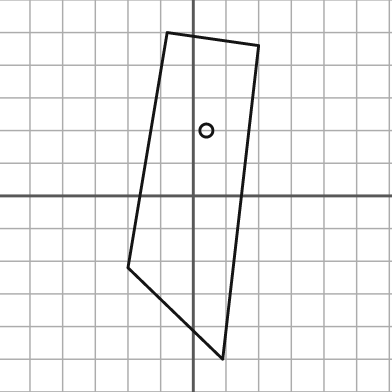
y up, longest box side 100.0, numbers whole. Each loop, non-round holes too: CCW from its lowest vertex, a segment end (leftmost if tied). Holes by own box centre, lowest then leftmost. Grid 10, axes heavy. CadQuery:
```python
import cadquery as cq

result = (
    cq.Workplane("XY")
    .moveTo(9.0, -50.0)
    .lineTo(20.0, 46.0)
    .lineTo(-8.0, 50.0)
    .lineTo(-20.0, -22.0)
    .close()
    .moveTo(4.0, 20.0)
    .circle(2.0)
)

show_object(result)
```